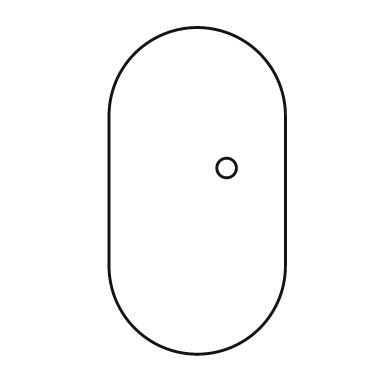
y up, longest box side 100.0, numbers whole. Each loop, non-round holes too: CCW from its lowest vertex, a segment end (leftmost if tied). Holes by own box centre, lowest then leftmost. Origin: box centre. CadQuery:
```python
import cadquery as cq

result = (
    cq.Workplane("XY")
    .moveTo(-27.0, -23.0)
    .threePointArc((0.0, -50.0), (27.0, -23.0))
    .lineTo(27.0, 23.0)
    .threePointArc((0.0, 50.0), (-27.0, 23.0))
    .close()
    .moveTo(9.0, 7.0)
    .circle(3.0)
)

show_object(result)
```